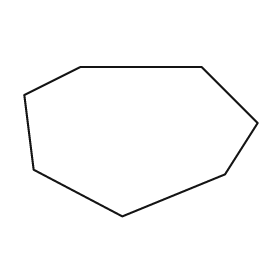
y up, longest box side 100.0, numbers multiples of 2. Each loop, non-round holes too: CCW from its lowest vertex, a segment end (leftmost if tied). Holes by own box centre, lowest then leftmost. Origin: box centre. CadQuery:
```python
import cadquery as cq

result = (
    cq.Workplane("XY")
    .moveTo(-8.0, -32.0)
    .lineTo(36.0, -14.0)
    .lineTo(50.0, 8.0)
    .lineTo(26.0, 32.0)
    .lineTo(-26.0, 32.0)
    .lineTo(-50.0, 20.0)
    .lineTo(-46.0, -12.0)
    .close()
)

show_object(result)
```